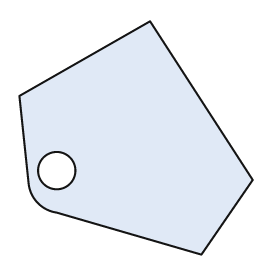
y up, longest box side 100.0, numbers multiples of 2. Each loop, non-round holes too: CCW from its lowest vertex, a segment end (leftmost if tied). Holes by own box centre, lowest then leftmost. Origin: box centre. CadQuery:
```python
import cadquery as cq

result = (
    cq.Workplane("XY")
    .moveTo(28.0, -50.0)
    .lineTo(50.0, -18.0)
    .lineTo(6.0, 50.0)
    .lineTo(-50.0, 18.0)
    .lineTo(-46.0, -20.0)
    .threePointArc((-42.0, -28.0), (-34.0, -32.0))
    .close()
    .moveTo(-34.0, -14.0)
    .circle(8.0)
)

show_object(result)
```